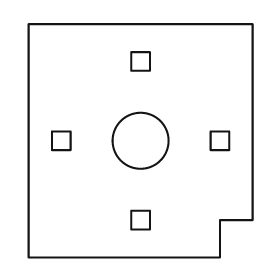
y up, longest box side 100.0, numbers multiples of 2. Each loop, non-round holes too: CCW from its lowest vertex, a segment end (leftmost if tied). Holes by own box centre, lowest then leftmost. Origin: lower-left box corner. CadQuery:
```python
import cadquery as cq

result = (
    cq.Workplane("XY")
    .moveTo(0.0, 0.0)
    .lineTo(82.0, 0.0)
    .lineTo(82.0, 16.0)
    .lineTo(96.0, 16.0)
    .lineTo(96.0, 100.0)
    .lineTo(0.0, 100.0)
    .close()
    .moveTo(44.0, 12.0)
    .lineTo(52.0, 12.0)
    .lineTo(52.0, 20.0)
    .lineTo(44.0, 20.0)
    .close()
    .moveTo(10.0, 46.0)
    .lineTo(18.0, 46.0)
    .lineTo(18.0, 54.0)
    .lineTo(10.0, 54.0)
    .close()
    .moveTo(48.0, 50.0)
    .circle(12.0)
    .moveTo(78.0, 46.0)
    .lineTo(86.0, 46.0)
    .lineTo(86.0, 54.0)
    .lineTo(78.0, 54.0)
    .close()
    .moveTo(44.0, 80.0)
    .lineTo(52.0, 80.0)
    .lineTo(52.0, 88.0)
    .lineTo(44.0, 88.0)
    .close()
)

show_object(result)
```